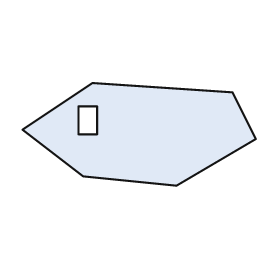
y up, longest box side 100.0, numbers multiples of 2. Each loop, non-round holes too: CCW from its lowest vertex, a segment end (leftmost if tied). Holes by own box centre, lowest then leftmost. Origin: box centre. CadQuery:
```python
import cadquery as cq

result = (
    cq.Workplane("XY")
    .moveTo(16.0, -22.0)
    .lineTo(50.0, -2.0)
    .lineTo(40.0, 18.0)
    .lineTo(-20.0, 22.0)
    .lineTo(-50.0, 2.0)
    .lineTo(-24.0, -18.0)
    .close()
    .moveTo(-26.0, 0.0)
    .lineTo(-18.0, 0.0)
    .lineTo(-18.0, 12.0)
    .lineTo(-26.0, 12.0)
    .close()
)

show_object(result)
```